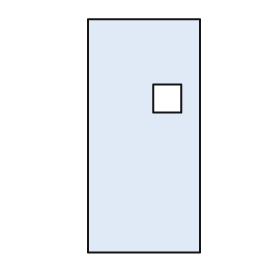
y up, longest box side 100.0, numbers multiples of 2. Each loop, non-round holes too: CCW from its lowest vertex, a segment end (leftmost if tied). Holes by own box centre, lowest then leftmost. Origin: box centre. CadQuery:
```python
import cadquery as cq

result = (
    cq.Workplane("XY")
    .moveTo(-24.0, -50.0)
    .lineTo(24.0, -50.0)
    .lineTo(24.0, 50.0)
    .lineTo(-24.0, 50.0)
    .close()
    .moveTo(4.0, 10.0)
    .lineTo(16.0, 10.0)
    .lineTo(16.0, 22.0)
    .lineTo(4.0, 22.0)
    .close()
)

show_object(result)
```